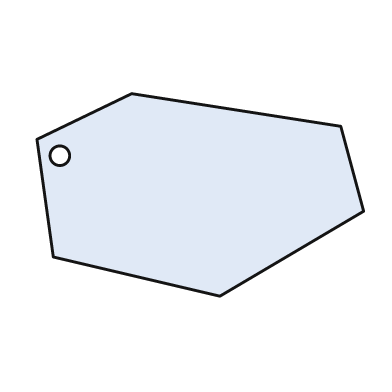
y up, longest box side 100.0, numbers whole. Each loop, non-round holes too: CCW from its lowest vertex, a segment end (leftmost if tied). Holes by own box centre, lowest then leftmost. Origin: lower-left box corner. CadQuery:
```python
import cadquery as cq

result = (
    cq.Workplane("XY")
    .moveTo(56.0, 0.0)
    .lineTo(100.0, 26.0)
    .lineTo(93.0, 52.0)
    .lineTo(29.0, 62.0)
    .lineTo(0.0, 48.0)
    .lineTo(5.0, 12.0)
    .close()
    .moveTo(7.0, 43.0)
    .circle(3.0)
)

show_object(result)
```